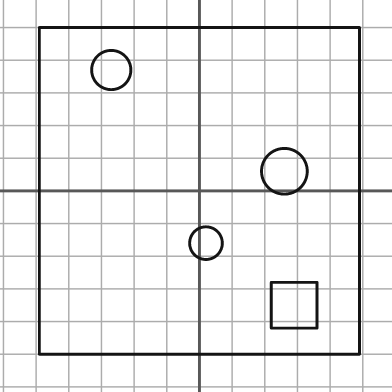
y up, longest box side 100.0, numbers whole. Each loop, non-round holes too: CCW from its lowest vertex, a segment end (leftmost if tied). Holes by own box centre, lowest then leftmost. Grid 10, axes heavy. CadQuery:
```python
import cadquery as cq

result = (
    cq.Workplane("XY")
    .moveTo(-49.0, -50.0)
    .lineTo(49.0, -50.0)
    .lineTo(49.0, 50.0)
    .lineTo(-49.0, 50.0)
    .close()
    .moveTo(22.0, -42.0)
    .lineTo(36.0, -42.0)
    .lineTo(36.0, -28.0)
    .lineTo(22.0, -28.0)
    .close()
    .moveTo(2.0, -16.0)
    .circle(5.0)
    .moveTo(26.0, 6.0)
    .circle(7.0)
    .moveTo(-27.0, 37.0)
    .circle(6.0)
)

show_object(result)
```